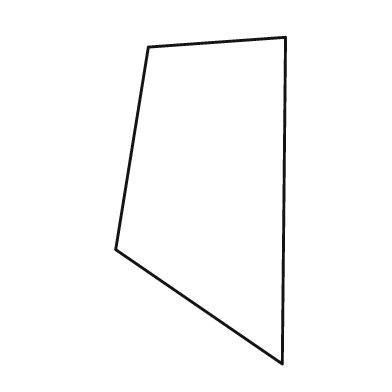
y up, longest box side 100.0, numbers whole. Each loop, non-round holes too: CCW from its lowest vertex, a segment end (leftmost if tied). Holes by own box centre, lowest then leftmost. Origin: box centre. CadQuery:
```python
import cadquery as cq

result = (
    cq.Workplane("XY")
    .moveTo(25.0, -50.0)
    .lineTo(26.0, 50.0)
    .lineTo(-16.0, 47.0)
    .lineTo(-26.0, -15.0)
    .close()
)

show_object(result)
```